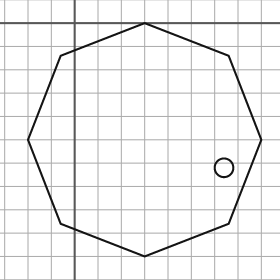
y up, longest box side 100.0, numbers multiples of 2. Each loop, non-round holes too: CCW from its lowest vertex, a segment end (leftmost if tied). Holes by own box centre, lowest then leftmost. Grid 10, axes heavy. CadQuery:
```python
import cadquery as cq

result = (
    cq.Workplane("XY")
    .moveTo(30.0, -100.0)
    .lineTo(66.0, -86.0)
    .lineTo(80.0, -50.0)
    .lineTo(66.0, -14.0)
    .lineTo(30.0, 0.0)
    .lineTo(-6.0, -14.0)
    .lineTo(-20.0, -50.0)
    .lineTo(-6.0, -86.0)
    .close()
    .moveTo(64.0, -62.0)
    .circle(4.0)
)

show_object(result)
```